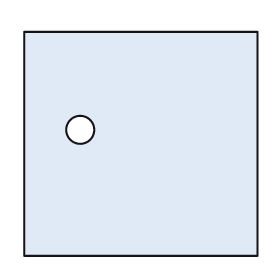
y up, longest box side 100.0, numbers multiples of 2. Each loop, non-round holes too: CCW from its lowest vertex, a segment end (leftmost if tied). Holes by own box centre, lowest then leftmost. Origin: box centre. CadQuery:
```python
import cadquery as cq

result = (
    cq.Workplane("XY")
    .moveTo(-50.0, -48.0)
    .lineTo(50.0, -48.0)
    .lineTo(50.0, 48.0)
    .lineTo(-50.0, 48.0)
    .close()
    .moveTo(-26.0, 6.0)
    .circle(6.0)
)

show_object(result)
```